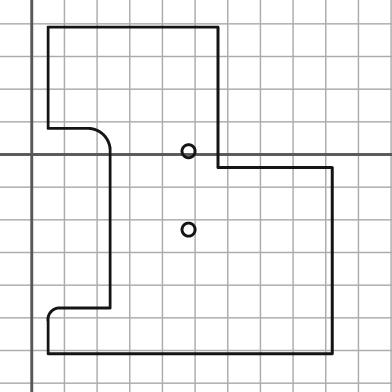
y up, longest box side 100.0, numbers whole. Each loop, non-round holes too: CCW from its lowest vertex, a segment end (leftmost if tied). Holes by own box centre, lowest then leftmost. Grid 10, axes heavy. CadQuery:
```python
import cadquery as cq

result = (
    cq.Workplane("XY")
    .moveTo(5.0, -61.0)
    .lineTo(92.0, -61.0)
    .lineTo(92.0, -4.0)
    .lineTo(57.0, -4.0)
    .lineTo(57.0, 39.0)
    .lineTo(5.0, 39.0)
    .lineTo(5.0, 8.0)
    .lineTo(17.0, 8.0)
    .threePointArc((22.0, 6.0), (24.0, 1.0))
    .lineTo(24.0, -47.0)
    .lineTo(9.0, -47.0)
    .threePointArc((6.0, -48.0), (5.0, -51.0))
    .close()
    .moveTo(48.0, -23.0)
    .circle(2.0)
    .moveTo(48.0, 1.0)
    .circle(2.0)
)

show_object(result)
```